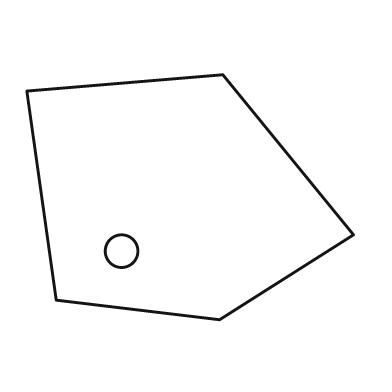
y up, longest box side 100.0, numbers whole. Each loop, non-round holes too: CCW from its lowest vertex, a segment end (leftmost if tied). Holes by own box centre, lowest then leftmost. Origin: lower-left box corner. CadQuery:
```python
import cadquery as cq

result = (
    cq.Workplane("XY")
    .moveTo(59.0, 0.0)
    .lineTo(100.0, 26.0)
    .lineTo(60.0, 75.0)
    .lineTo(0.0, 70.0)
    .lineTo(9.0, 6.0)
    .close()
    .moveTo(29.0, 21.0)
    .circle(5.0)
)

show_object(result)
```